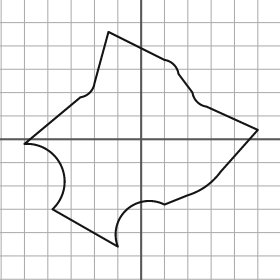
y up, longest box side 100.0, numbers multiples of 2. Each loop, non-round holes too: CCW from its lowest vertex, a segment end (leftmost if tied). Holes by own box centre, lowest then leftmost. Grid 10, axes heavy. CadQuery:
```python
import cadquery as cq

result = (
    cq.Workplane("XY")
    .moveTo(-10.0, -46.0)
    .threePointArc((-6.0, -30.0), (10.0, -28.0))
    .lineTo(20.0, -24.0)
    .threePointArc((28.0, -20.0), (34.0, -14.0))
    .lineTo(50.0, 4.0)
    .lineTo(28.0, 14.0)
    .threePointArc((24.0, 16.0), (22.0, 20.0))
    .lineTo(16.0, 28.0)
    .threePointArc((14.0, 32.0), (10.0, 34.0))
    .lineTo(-14.0, 46.0)
    .lineTo(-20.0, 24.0)
    .threePointArc((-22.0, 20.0), (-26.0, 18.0))
    .lineTo(-50.0, -2.0)
    .threePointArc((-34.0, -12.0), (-38.0, -30.0))
    .close()
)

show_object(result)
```